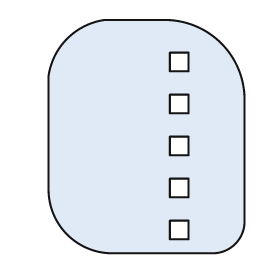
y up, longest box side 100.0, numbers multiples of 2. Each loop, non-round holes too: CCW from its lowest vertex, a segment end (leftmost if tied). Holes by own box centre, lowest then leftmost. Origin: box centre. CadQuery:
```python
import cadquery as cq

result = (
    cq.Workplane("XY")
    .moveTo(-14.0, -50.0)
    .lineTo(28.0, -50.0)
    .threePointArc((38.0, -46.0), (42.0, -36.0))
    .lineTo(42.0, 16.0)
    .threePointArc((32.0, 40.0), (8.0, 50.0))
    .lineTo(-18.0, 50.0)
    .threePointArc((-34.0, 42.0), (-42.0, 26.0))
    .lineTo(-42.0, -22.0)
    .threePointArc((-34.0, -42.0), (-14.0, -50.0))
    .close()
    .moveTo(10.0, -44.0)
    .lineTo(18.0, -44.0)
    .lineTo(18.0, -36.0)
    .lineTo(10.0, -36.0)
    .close()
    .moveTo(10.0, -26.0)
    .lineTo(18.0, -26.0)
    .lineTo(18.0, -18.0)
    .lineTo(10.0, -18.0)
    .close()
    .moveTo(10.0, -8.0)
    .lineTo(18.0, -8.0)
    .lineTo(18.0, 0.0)
    .lineTo(10.0, 0.0)
    .close()
    .moveTo(10.0, 10.0)
    .lineTo(18.0, 10.0)
    .lineTo(18.0, 18.0)
    .lineTo(10.0, 18.0)
    .close()
    .moveTo(10.0, 28.0)
    .lineTo(18.0, 28.0)
    .lineTo(18.0, 36.0)
    .lineTo(10.0, 36.0)
    .close()
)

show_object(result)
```